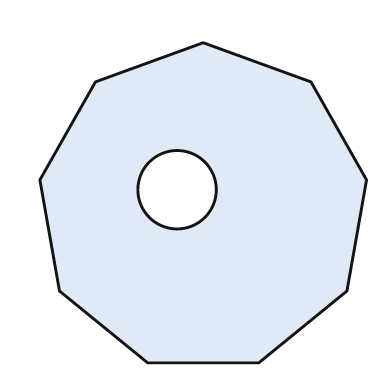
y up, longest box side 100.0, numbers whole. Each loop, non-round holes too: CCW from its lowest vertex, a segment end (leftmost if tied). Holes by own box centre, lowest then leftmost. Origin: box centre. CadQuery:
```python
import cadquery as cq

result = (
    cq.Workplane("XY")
    .moveTo(-17.0, -49.0)
    .lineTo(17.0, -49.0)
    .lineTo(44.0, -27.0)
    .lineTo(50.0, 7.0)
    .lineTo(33.0, 37.0)
    .lineTo(0.0, 49.0)
    .lineTo(-33.0, 37.0)
    .lineTo(-50.0, 7.0)
    .lineTo(-44.0, -27.0)
    .close()
    .moveTo(-8.0, 4.0)
    .circle(12.0)
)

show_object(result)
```